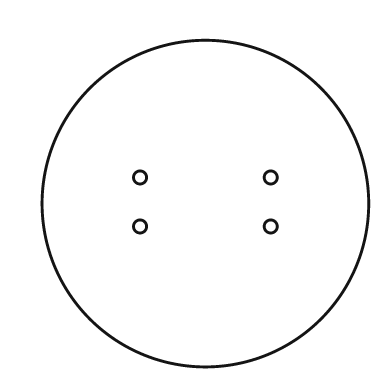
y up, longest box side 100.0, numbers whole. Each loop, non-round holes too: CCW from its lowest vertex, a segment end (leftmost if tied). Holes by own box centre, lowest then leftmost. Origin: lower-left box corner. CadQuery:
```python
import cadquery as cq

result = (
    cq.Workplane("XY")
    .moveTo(50.0, 50.0)
    .circle(50.0)
    .moveTo(30.0, 43.0)
    .circle(2.0)
    .moveTo(70.0, 43.0)
    .circle(2.0)
    .moveTo(30.0, 58.0)
    .circle(2.0)
    .moveTo(70.0, 58.0)
    .circle(2.0)
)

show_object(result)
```